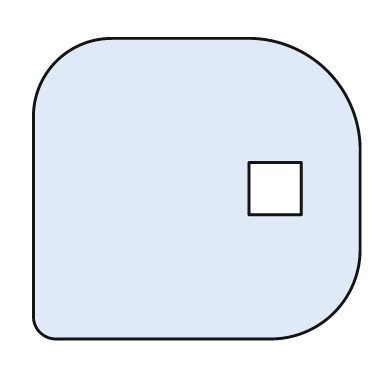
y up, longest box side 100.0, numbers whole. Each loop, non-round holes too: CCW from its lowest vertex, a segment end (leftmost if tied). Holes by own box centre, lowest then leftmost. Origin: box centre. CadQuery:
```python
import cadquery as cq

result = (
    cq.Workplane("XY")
    .moveTo(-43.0, -46.0)
    .lineTo(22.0, -46.0)
    .threePointArc((42.0, -38.0), (50.0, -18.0))
    .lineTo(50.0, 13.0)
    .threePointArc((40.0, 36.0), (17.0, 46.0))
    .lineTo(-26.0, 46.0)
    .threePointArc((-43.0, 39.0), (-50.0, 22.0))
    .lineTo(-50.0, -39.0)
    .threePointArc((-48.0, -44.0), (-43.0, -46.0))
    .close()
    .moveTo(16.0, -8.0)
    .lineTo(32.0, -8.0)
    .lineTo(32.0, 8.0)
    .lineTo(16.0, 8.0)
    .close()
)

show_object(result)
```